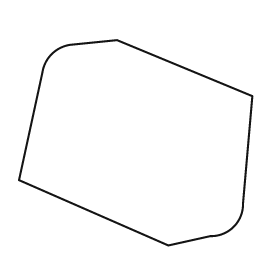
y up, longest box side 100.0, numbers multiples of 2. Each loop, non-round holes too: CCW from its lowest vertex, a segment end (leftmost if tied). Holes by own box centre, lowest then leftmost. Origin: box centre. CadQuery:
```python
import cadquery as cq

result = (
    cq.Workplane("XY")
    .moveTo(14.0, -44.0)
    .lineTo(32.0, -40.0)
    .threePointArc((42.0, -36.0), (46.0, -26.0))
    .lineTo(50.0, 20.0)
    .lineTo(-8.0, 44.0)
    .lineTo(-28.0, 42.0)
    .threePointArc((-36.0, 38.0), (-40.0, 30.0))
    .lineTo(-50.0, -16.0)
    .close()
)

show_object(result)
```